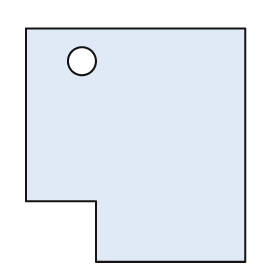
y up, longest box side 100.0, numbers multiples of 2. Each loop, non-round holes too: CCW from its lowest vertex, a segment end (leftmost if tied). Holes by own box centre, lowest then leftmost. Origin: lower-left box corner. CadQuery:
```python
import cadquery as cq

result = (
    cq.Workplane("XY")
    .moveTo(30.0, 0.0)
    .lineTo(94.0, 0.0)
    .lineTo(94.0, 100.0)
    .lineTo(0.0, 100.0)
    .lineTo(0.0, 26.0)
    .lineTo(30.0, 26.0)
    .close()
    .moveTo(24.0, 86.0)
    .circle(6.0)
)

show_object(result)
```